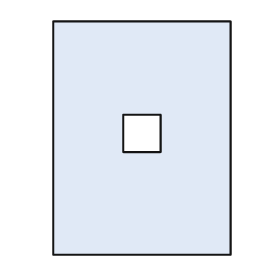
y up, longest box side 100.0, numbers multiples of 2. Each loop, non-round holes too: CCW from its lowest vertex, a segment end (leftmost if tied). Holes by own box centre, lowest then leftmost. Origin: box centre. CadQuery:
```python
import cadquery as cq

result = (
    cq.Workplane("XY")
    .moveTo(-38.0, -50.0)
    .lineTo(38.0, -50.0)
    .lineTo(38.0, 50.0)
    .lineTo(-38.0, 50.0)
    .close()
    .moveTo(-8.0, -6.0)
    .lineTo(8.0, -6.0)
    .lineTo(8.0, 10.0)
    .lineTo(-8.0, 10.0)
    .close()
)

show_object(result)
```